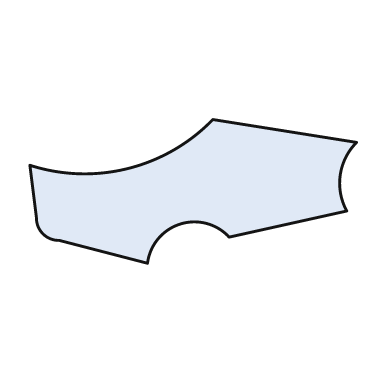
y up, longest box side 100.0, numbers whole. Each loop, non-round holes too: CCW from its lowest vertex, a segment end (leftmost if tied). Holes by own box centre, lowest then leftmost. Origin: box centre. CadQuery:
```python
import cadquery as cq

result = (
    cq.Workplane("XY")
    .moveTo(-14.0, -22.0)
    .threePointArc((-4.0, -10.0), (11.0, -14.0))
    .lineTo(47.0, -6.0)
    .threePointArc((45.0, 5.0), (50.0, 15.0))
    .lineTo(6.0, 22.0)
    .threePointArc((-20.0, 7.0), (-50.0, 8.0))
    .lineTo(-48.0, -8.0)
    .threePointArc((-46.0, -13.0), (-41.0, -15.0))
    .close()
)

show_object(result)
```